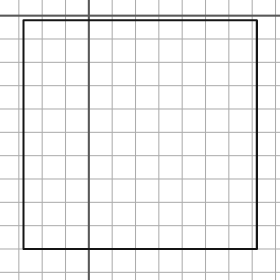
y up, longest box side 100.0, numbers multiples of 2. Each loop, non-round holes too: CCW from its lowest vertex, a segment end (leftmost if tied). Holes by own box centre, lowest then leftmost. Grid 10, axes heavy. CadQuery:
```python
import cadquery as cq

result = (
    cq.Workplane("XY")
    .moveTo(-28.0, -100.0)
    .lineTo(72.0, -100.0)
    .lineTo(72.0, -2.0)
    .lineTo(-28.0, -2.0)
    .close()
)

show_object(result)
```